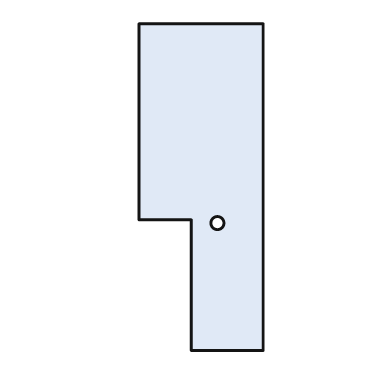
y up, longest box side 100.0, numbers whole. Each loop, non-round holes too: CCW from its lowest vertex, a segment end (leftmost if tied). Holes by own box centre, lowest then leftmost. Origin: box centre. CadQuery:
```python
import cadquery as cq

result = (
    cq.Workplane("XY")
    .moveTo(-3.0, -50.0)
    .lineTo(19.0, -50.0)
    .lineTo(19.0, 50.0)
    .lineTo(-19.0, 50.0)
    .lineTo(-19.0, -10.0)
    .lineTo(-3.0, -10.0)
    .close()
    .moveTo(5.0, -11.0)
    .circle(2.0)
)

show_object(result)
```